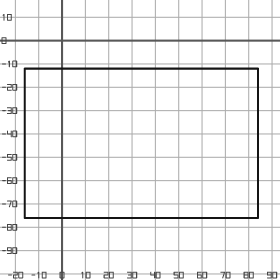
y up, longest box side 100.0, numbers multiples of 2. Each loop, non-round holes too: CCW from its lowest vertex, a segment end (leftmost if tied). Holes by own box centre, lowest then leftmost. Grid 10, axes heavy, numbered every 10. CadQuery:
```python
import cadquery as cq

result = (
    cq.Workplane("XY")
    .moveTo(-16.0, -76.0)
    .lineTo(84.0, -76.0)
    .lineTo(84.0, -12.0)
    .lineTo(-16.0, -12.0)
    .close()
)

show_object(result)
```